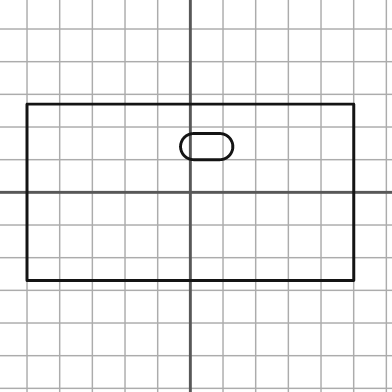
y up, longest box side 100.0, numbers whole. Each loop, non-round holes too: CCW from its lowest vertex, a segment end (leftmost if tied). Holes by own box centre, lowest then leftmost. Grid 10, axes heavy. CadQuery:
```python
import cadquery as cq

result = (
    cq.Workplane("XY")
    .moveTo(-50.0, -27.0)
    .lineTo(50.0, -27.0)
    .lineTo(50.0, 27.0)
    .lineTo(-50.0, 27.0)
    .close()
    .moveTo(1.0, 10.0)
    .lineTo(9.0, 10.0)
    .threePointArc((13.0, 14.0), (9.0, 18.0))
    .lineTo(1.0, 18.0)
    .threePointArc((-3.0, 14.0), (1.0, 10.0))
    .close()
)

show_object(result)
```